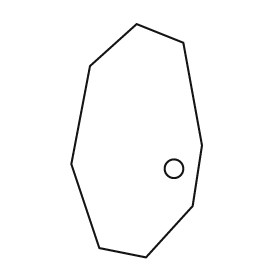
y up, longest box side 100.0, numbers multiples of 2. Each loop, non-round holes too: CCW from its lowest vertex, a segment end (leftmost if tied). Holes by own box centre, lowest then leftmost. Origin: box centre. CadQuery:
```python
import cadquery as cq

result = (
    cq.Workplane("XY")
    .moveTo(4.0, -50.0)
    .lineTo(24.0, -28.0)
    .lineTo(28.0, -2.0)
    .lineTo(20.0, 42.0)
    .lineTo(0.0, 50.0)
    .lineTo(-20.0, 32.0)
    .lineTo(-28.0, -10.0)
    .lineTo(-16.0, -46.0)
    .close()
    .moveTo(16.0, -12.0)
    .circle(4.0)
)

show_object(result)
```